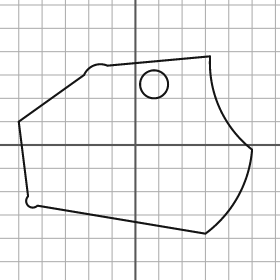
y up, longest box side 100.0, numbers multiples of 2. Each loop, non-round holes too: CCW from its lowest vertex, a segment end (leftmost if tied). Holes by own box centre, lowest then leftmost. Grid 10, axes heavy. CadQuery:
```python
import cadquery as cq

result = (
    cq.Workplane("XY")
    .moveTo(30.0, -38.0)
    .threePointArc((44.0, -22.0), (50.0, -2.0))
    .threePointArc((36.0, 16.0), (32.0, 38.0))
    .lineTo(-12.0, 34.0)
    .threePointArc((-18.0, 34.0), (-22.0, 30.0))
    .lineTo(-50.0, 10.0)
    .lineTo(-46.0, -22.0)
    .threePointArc((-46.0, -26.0), (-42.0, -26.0))
    .close()
    .moveTo(8.0, 26.0)
    .circle(6.0)
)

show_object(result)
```